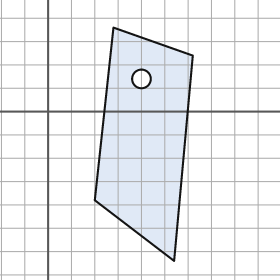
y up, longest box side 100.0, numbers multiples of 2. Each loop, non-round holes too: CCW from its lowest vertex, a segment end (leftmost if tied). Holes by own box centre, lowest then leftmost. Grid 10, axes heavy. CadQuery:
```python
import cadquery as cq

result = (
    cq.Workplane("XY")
    .moveTo(54.0, -64.0)
    .lineTo(62.0, 24.0)
    .lineTo(28.0, 36.0)
    .lineTo(20.0, -38.0)
    .close()
    .moveTo(40.0, 14.0)
    .circle(4.0)
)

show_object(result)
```